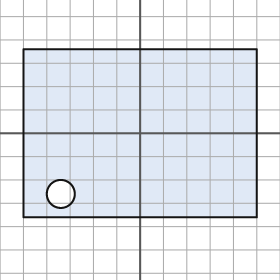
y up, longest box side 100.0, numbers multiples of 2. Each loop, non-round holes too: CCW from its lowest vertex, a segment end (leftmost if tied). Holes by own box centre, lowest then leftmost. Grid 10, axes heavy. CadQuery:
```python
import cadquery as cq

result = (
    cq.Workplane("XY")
    .moveTo(-50.0, -36.0)
    .lineTo(50.0, -36.0)
    .lineTo(50.0, 36.0)
    .lineTo(-50.0, 36.0)
    .close()
    .moveTo(-34.0, -26.0)
    .circle(6.0)
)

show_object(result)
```